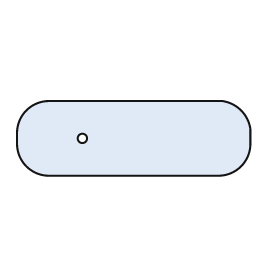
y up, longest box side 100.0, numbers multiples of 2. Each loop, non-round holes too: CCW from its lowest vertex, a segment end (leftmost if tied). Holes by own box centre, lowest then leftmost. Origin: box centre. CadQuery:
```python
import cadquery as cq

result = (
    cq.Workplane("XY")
    .moveTo(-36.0, -16.0)
    .lineTo(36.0, -16.0)
    .threePointArc((46.0, -12.0), (50.0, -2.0))
    .lineTo(50.0, 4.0)
    .threePointArc((46.0, 12.0), (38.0, 16.0))
    .lineTo(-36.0, 16.0)
    .threePointArc((-46.0, 12.0), (-50.0, 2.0))
    .lineTo(-50.0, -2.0)
    .threePointArc((-46.0, -12.0), (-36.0, -16.0))
    .close()
    .moveTo(-22.0, 0.0)
    .circle(2.0)
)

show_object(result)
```